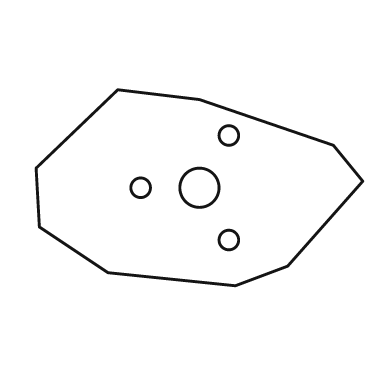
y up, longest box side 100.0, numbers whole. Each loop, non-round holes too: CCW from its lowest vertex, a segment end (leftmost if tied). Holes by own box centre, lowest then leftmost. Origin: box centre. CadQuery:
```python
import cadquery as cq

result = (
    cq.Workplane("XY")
    .moveTo(11.0, -30.0)
    .lineTo(27.0, -24.0)
    .lineTo(50.0, 2.0)
    .lineTo(41.0, 13.0)
    .lineTo(0.0, 27.0)
    .lineTo(-25.0, 30.0)
    .lineTo(-50.0, 6.0)
    .lineTo(-49.0, -12.0)
    .lineTo(-28.0, -26.0)
    .close()
    .moveTo(9.0, -16.0)
    .circle(3.0)
    .moveTo(-18.0, 0.0)
    .circle(3.0)
    .moveTo(0.0, 0.0)
    .circle(6.0)
    .moveTo(9.0, 16.0)
    .circle(3.0)
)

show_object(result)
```